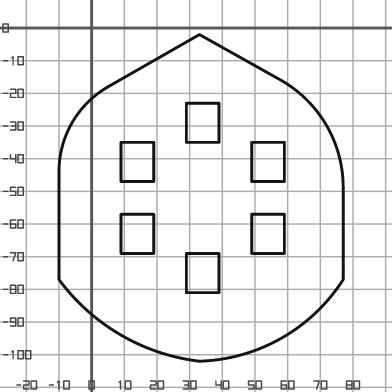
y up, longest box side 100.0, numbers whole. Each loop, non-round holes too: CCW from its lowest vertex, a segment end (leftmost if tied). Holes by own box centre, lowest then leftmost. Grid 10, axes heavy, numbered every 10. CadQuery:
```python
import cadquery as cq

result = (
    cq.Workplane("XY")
    .moveTo(33.0, -102.0)
    .threePointArc((58.0, -95.0), (77.0, -77.0))
    .lineTo(77.0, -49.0)
    .threePointArc((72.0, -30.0), (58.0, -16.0))
    .lineTo(33.0, -2.0)
    .lineTo(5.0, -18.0)
    .threePointArc((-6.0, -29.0), (-10.0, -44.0))
    .lineTo(-10.0, -77.0)
    .threePointArc((9.0, -94.0), (33.0, -102.0))
    .close()
    .moveTo(29.0, -81.0)
    .lineTo(39.0, -81.0)
    .lineTo(39.0, -69.0)
    .lineTo(29.0, -69.0)
    .close()
    .moveTo(9.0, -69.0)
    .lineTo(19.0, -69.0)
    .lineTo(19.0, -57.0)
    .lineTo(9.0, -57.0)
    .close()
    .moveTo(49.0, -69.0)
    .lineTo(59.0, -69.0)
    .lineTo(59.0, -57.0)
    .lineTo(49.0, -57.0)
    .close()
    .moveTo(9.0, -47.0)
    .lineTo(19.0, -47.0)
    .lineTo(19.0, -35.0)
    .lineTo(9.0, -35.0)
    .close()
    .moveTo(49.0, -47.0)
    .lineTo(59.0, -47.0)
    .lineTo(59.0, -35.0)
    .lineTo(49.0, -35.0)
    .close()
    .moveTo(29.0, -35.0)
    .lineTo(39.0, -35.0)
    .lineTo(39.0, -23.0)
    .lineTo(29.0, -23.0)
    .close()
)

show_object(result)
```